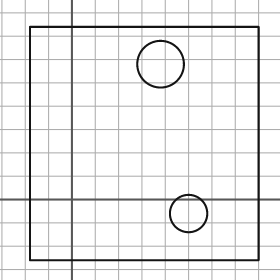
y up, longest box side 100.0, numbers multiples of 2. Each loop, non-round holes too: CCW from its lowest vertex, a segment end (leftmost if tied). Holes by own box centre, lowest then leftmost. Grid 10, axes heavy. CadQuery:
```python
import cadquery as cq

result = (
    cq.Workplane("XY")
    .moveTo(-18.0, -26.0)
    .lineTo(80.0, -26.0)
    .lineTo(80.0, 74.0)
    .lineTo(-18.0, 74.0)
    .close()
    .moveTo(50.0, -6.0)
    .circle(8.0)
    .moveTo(38.0, 58.0)
    .circle(10.0)
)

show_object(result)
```